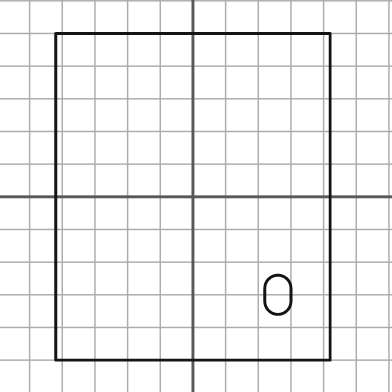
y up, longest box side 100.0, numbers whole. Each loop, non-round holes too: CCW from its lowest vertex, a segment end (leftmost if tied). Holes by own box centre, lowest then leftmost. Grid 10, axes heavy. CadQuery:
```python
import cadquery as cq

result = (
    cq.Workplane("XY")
    .moveTo(-42.0, -50.0)
    .lineTo(42.0, -50.0)
    .lineTo(42.0, 50.0)
    .lineTo(-42.0, 50.0)
    .close()
    .moveTo(22.0, -32.0)
    .threePointArc((26.0, -36.0), (30.0, -32.0))
    .lineTo(30.0, -28.0)
    .threePointArc((26.0, -24.0), (22.0, -28.0))
    .close()
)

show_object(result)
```